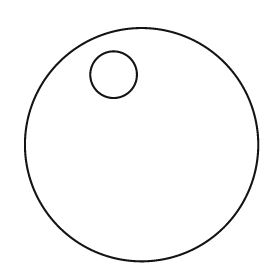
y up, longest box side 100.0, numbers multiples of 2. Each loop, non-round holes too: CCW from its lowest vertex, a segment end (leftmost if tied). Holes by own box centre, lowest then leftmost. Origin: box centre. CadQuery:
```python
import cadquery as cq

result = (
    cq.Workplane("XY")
    .moveTo(0.0, 0.0)
    .circle(50.0)
    .moveTo(-12.0, 30.0)
    .circle(10.0)
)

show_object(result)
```